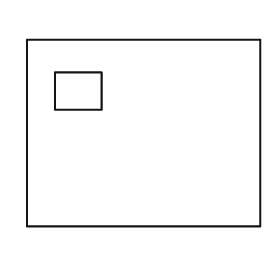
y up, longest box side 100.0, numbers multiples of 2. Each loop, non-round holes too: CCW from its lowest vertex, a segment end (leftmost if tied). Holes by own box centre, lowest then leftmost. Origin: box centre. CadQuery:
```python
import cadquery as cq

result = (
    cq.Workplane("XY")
    .moveTo(-50.0, -40.0)
    .lineTo(50.0, -40.0)
    .lineTo(50.0, 40.0)
    .lineTo(-50.0, 40.0)
    .close()
    .moveTo(-38.0, 10.0)
    .lineTo(-18.0, 10.0)
    .lineTo(-18.0, 26.0)
    .lineTo(-38.0, 26.0)
    .close()
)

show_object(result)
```